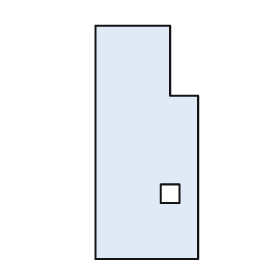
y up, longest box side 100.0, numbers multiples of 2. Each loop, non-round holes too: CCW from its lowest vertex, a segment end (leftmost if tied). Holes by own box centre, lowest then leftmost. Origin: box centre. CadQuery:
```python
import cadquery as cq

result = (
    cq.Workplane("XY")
    .moveTo(-22.0, -50.0)
    .lineTo(22.0, -50.0)
    .lineTo(22.0, 20.0)
    .lineTo(10.0, 20.0)
    .lineTo(10.0, 50.0)
    .lineTo(-22.0, 50.0)
    .close()
    .moveTo(6.0, -26.0)
    .lineTo(14.0, -26.0)
    .lineTo(14.0, -18.0)
    .lineTo(6.0, -18.0)
    .close()
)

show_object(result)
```